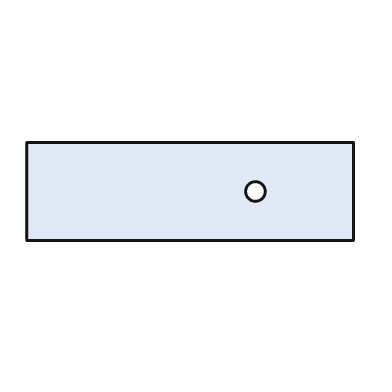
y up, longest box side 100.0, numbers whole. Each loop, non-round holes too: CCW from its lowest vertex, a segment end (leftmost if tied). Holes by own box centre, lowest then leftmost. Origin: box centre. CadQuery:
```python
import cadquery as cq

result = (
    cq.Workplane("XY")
    .moveTo(-50.0, -15.0)
    .lineTo(50.0, -15.0)
    .lineTo(50.0, 15.0)
    .lineTo(-50.0, 15.0)
    .close()
    .moveTo(20.0, 0.0)
    .circle(3.0)
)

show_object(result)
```